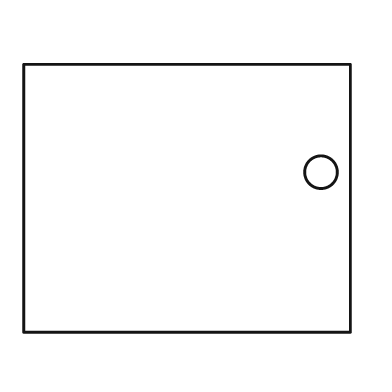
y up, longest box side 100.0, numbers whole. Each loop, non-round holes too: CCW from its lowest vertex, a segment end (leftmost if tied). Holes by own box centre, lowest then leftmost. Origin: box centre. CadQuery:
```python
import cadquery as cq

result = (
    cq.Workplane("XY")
    .moveTo(-50.0, -41.0)
    .lineTo(50.0, -41.0)
    .lineTo(50.0, 41.0)
    .lineTo(-50.0, 41.0)
    .close()
    .moveTo(41.0, 8.0)
    .circle(5.0)
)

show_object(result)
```